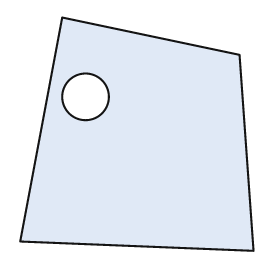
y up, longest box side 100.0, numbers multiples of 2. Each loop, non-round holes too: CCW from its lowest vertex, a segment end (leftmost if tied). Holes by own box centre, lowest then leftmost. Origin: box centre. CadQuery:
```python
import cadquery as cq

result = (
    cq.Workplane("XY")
    .moveTo(50.0, -50.0)
    .lineTo(44.0, 34.0)
    .lineTo(-32.0, 50.0)
    .lineTo(-50.0, -46.0)
    .close()
    .moveTo(-22.0, 16.0)
    .circle(10.0)
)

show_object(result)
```